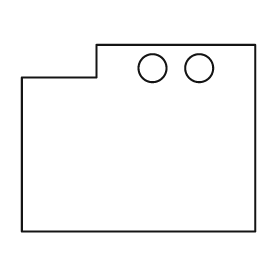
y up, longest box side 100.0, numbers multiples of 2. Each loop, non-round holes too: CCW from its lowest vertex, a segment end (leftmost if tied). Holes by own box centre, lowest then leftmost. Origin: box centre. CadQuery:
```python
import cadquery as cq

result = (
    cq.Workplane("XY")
    .moveTo(-50.0, -40.0)
    .lineTo(50.0, -40.0)
    .lineTo(50.0, 40.0)
    .lineTo(-18.0, 40.0)
    .lineTo(-18.0, 26.0)
    .lineTo(-50.0, 26.0)
    .close()
    .moveTo(6.0, 30.0)
    .circle(6.0)
    .moveTo(26.0, 30.0)
    .circle(6.0)
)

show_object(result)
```